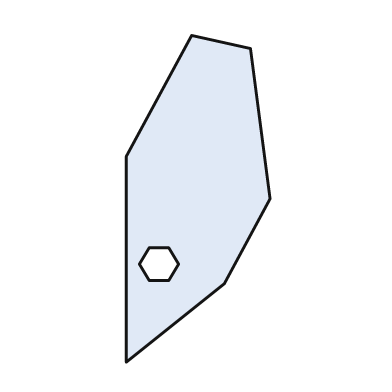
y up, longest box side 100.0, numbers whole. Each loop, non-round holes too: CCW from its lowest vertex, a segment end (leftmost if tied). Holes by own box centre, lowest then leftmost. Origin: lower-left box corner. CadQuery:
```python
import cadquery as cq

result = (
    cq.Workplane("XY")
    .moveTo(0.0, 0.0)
    .lineTo(30.0, 24.0)
    .lineTo(44.0, 50.0)
    .lineTo(38.0, 96.0)
    .lineTo(20.0, 100.0)
    .lineTo(0.0, 63.0)
    .close()
    .moveTo(7.0, 25.0)
    .lineTo(13.0, 25.0)
    .lineTo(16.0, 30.0)
    .lineTo(13.0, 35.0)
    .lineTo(7.0, 35.0)
    .lineTo(4.0, 30.0)
    .close()
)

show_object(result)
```